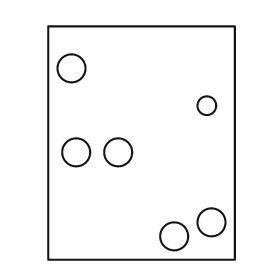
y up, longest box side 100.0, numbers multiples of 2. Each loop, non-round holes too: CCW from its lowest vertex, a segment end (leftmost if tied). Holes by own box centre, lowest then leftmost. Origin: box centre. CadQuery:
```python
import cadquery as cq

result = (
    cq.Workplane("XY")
    .moveTo(-40.0, -50.0)
    .lineTo(40.0, -50.0)
    .lineTo(40.0, 50.0)
    .lineTo(-40.0, 50.0)
    .close()
    .moveTo(14.0, -40.0)
    .circle(6.0)
    .moveTo(30.0, -34.0)
    .circle(6.0)
    .moveTo(-28.0, -4.0)
    .circle(6.0)
    .moveTo(-10.0, -4.0)
    .circle(6.0)
    .moveTo(28.0, 16.0)
    .circle(4.0)
    .moveTo(-30.0, 32.0)
    .circle(6.0)
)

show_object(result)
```